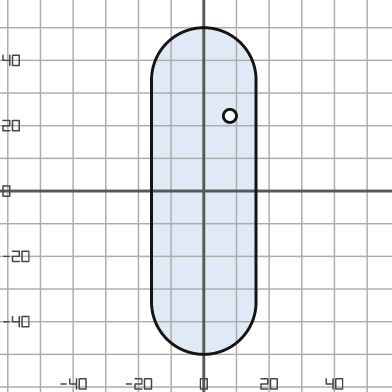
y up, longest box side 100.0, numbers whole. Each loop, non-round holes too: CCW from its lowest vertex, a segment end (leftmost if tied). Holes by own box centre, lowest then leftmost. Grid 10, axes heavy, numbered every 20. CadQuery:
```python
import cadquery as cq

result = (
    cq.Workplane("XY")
    .moveTo(-16.0, -34.0)
    .threePointArc((0.0, -50.0), (16.0, -34.0))
    .lineTo(16.0, 34.0)
    .threePointArc((0.0, 50.0), (-16.0, 34.0))
    .close()
    .moveTo(8.0, 23.0)
    .circle(2.0)
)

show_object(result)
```